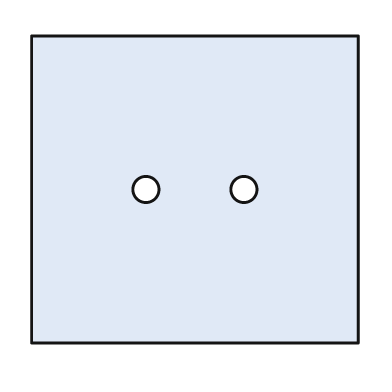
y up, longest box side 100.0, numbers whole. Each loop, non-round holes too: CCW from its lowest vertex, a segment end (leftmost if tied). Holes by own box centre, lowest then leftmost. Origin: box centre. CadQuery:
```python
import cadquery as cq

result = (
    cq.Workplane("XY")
    .moveTo(-50.0, -47.0)
    .lineTo(50.0, -47.0)
    .lineTo(50.0, 47.0)
    .lineTo(-50.0, 47.0)
    .close()
    .moveTo(-15.0, 0.0)
    .circle(4.0)
    .moveTo(15.0, 0.0)
    .circle(4.0)
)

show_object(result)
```